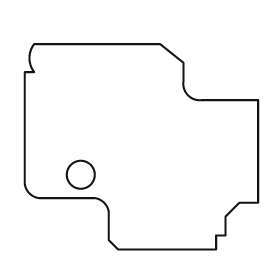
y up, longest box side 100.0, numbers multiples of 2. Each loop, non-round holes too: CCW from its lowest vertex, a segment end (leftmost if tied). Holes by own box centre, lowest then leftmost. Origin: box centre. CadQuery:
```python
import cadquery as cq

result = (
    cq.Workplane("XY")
    .moveTo(-10.0, -44.0)
    .lineTo(32.0, -44.0)
    .lineTo(32.0, -38.0)
    .lineTo(36.0, -38.0)
    .lineTo(36.0, -30.0)
    .lineTo(42.0, -24.0)
    .lineTo(50.0, -24.0)
    .lineTo(50.0, 20.0)
    .lineTo(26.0, 20.0)
    .threePointArc((20.0, 22.0), (18.0, 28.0))
    .lineTo(18.0, 36.0)
    .lineTo(8.0, 44.0)
    .lineTo(-46.0, 44.0)
    .threePointArc((-48.0, 38.0), (-46.0, 32.0))
    .lineTo(-50.0, 32.0)
    .lineTo(-50.0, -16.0)
    .threePointArc((-48.0, -20.0), (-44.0, -22.0))
    .lineTo(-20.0, -22.0)
    .threePointArc((-16.0, -24.0), (-14.0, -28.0))
    .lineTo(-14.0, -40.0)
    .close()
    .moveTo(-26.0, -12.0)
    .circle(6.0)
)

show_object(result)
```